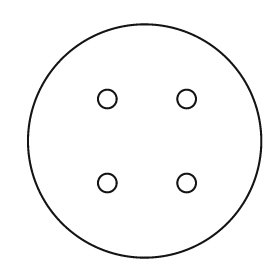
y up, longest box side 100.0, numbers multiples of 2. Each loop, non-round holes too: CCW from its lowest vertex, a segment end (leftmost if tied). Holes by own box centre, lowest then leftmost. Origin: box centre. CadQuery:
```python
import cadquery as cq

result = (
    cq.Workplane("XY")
    .moveTo(0.0, 0.0)
    .circle(50.0)
    .moveTo(-16.0, -18.0)
    .circle(4.0)
    .moveTo(18.0, -18.0)
    .circle(4.0)
    .moveTo(-16.0, 18.0)
    .circle(4.0)
    .moveTo(18.0, 18.0)
    .circle(4.0)
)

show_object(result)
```